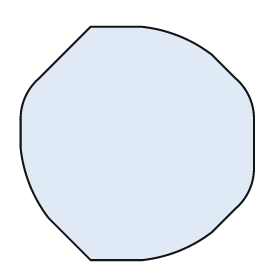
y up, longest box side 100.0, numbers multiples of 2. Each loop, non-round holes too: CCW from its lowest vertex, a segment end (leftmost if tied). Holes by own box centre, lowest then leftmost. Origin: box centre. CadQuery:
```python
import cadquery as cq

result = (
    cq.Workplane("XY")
    .moveTo(-20.0, -50.0)
    .lineTo(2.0, -50.0)
    .threePointArc((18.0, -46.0), (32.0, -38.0))
    .lineTo(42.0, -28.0)
    .threePointArc((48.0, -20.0), (50.0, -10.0))
    .lineTo(50.0, 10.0)
    .threePointArc((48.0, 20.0), (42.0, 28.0))
    .lineTo(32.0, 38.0)
    .threePointArc((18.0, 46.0), (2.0, 50.0))
    .lineTo(-20.0, 50.0)
    .lineTo(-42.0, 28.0)
    .threePointArc((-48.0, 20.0), (-50.0, 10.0))
    .lineTo(-50.0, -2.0)
    .threePointArc((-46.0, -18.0), (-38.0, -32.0))
    .close()
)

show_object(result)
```